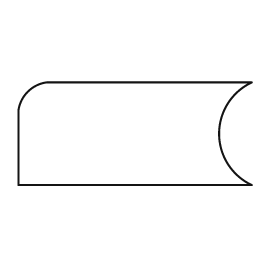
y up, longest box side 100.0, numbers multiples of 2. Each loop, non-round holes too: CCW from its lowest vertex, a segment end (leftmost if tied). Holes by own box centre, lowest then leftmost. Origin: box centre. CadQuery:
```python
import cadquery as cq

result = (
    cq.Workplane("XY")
    .moveTo(-50.0, -22.0)
    .lineTo(50.0, -22.0)
    .threePointArc((36.0, 0.0), (50.0, 22.0))
    .lineTo(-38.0, 22.0)
    .threePointArc((-46.0, 18.0), (-50.0, 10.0))
    .close()
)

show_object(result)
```